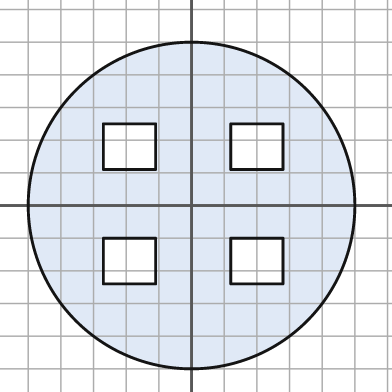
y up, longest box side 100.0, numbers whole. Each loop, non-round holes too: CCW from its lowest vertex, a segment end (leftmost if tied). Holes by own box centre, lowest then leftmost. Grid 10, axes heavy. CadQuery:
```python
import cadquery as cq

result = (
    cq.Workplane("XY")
    .moveTo(0.0, 0.0)
    .circle(50.0)
    .moveTo(-27.0, -24.0)
    .lineTo(-11.0, -24.0)
    .lineTo(-11.0, -10.0)
    .lineTo(-27.0, -10.0)
    .close()
    .moveTo(12.0, -24.0)
    .lineTo(28.0, -24.0)
    .lineTo(28.0, -10.0)
    .lineTo(12.0, -10.0)
    .close()
    .moveTo(-27.0, 11.0)
    .lineTo(-11.0, 11.0)
    .lineTo(-11.0, 25.0)
    .lineTo(-27.0, 25.0)
    .close()
    .moveTo(12.0, 11.0)
    .lineTo(28.0, 11.0)
    .lineTo(28.0, 25.0)
    .lineTo(12.0, 25.0)
    .close()
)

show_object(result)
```